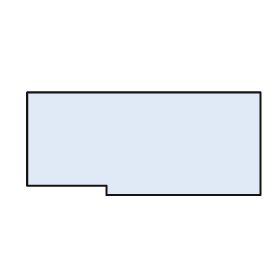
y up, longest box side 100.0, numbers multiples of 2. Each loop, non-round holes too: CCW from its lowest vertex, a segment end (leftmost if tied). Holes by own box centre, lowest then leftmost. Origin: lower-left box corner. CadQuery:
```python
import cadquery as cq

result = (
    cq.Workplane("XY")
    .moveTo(34.0, 0.0)
    .lineTo(100.0, 0.0)
    .lineTo(100.0, 44.0)
    .lineTo(0.0, 44.0)
    .lineTo(0.0, 4.0)
    .lineTo(34.0, 4.0)
    .close()
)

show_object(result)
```